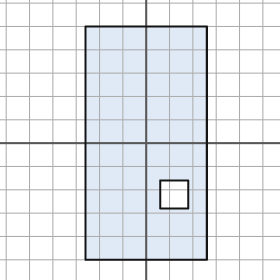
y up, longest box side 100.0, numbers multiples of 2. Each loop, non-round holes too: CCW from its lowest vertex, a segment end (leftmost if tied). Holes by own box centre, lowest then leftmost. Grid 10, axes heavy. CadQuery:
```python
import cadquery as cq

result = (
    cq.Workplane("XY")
    .moveTo(-26.0, -50.0)
    .lineTo(26.0, -50.0)
    .lineTo(26.0, 50.0)
    .lineTo(-26.0, 50.0)
    .close()
    .moveTo(6.0, -28.0)
    .lineTo(18.0, -28.0)
    .lineTo(18.0, -16.0)
    .lineTo(6.0, -16.0)
    .close()
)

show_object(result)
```